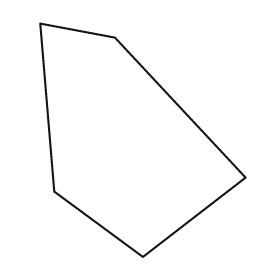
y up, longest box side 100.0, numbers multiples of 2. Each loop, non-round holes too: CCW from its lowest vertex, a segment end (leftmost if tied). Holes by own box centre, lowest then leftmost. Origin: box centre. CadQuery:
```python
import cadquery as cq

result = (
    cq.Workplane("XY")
    .moveTo(0.0, -50.0)
    .lineTo(44.0, -16.0)
    .lineTo(-12.0, 44.0)
    .lineTo(-44.0, 50.0)
    .lineTo(-38.0, -22.0)
    .close()
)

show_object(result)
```